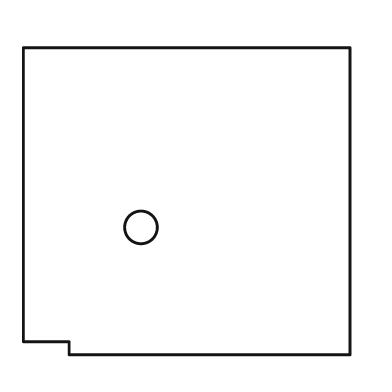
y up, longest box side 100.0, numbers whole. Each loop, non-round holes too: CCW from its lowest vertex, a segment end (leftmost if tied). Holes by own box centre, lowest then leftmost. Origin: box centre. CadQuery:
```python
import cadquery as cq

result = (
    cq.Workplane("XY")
    .moveTo(-36.0, -47.0)
    .lineTo(50.0, -47.0)
    .lineTo(50.0, 47.0)
    .lineTo(-50.0, 47.0)
    .lineTo(-50.0, -43.0)
    .lineTo(-36.0, -43.0)
    .close()
    .moveTo(-14.0, -8.0)
    .circle(5.0)
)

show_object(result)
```